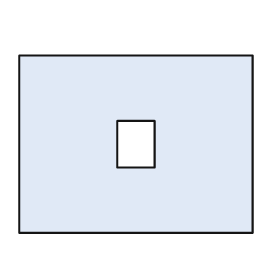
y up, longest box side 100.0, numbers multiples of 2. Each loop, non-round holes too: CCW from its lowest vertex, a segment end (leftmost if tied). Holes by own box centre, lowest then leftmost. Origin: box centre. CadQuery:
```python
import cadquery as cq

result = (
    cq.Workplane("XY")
    .moveTo(-50.0, -38.0)
    .lineTo(50.0, -38.0)
    .lineTo(50.0, 38.0)
    .lineTo(-50.0, 38.0)
    .close()
    .moveTo(-8.0, -10.0)
    .lineTo(8.0, -10.0)
    .lineTo(8.0, 10.0)
    .lineTo(-8.0, 10.0)
    .close()
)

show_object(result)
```